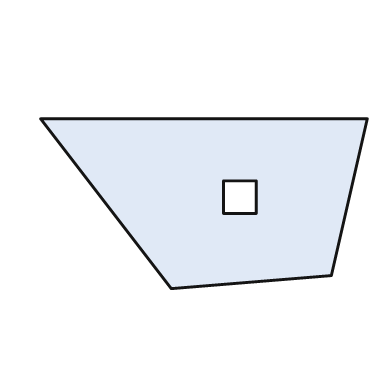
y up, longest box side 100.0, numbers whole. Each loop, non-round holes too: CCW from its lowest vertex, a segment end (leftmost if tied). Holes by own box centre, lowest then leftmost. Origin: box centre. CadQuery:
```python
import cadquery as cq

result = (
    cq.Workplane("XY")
    .moveTo(-10.0, -26.0)
    .lineTo(39.0, -22.0)
    .lineTo(50.0, 26.0)
    .lineTo(-50.0, 26.0)
    .close()
    .moveTo(6.0, -3.0)
    .lineTo(16.0, -3.0)
    .lineTo(16.0, 7.0)
    .lineTo(6.0, 7.0)
    .close()
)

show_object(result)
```